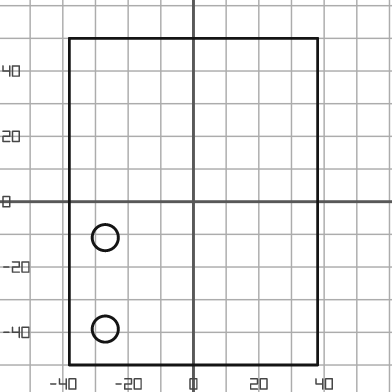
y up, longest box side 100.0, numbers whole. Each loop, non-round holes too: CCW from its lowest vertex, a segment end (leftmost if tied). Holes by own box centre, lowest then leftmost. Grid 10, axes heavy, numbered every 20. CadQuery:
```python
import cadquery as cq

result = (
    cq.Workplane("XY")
    .moveTo(-38.0, -50.0)
    .lineTo(38.0, -50.0)
    .lineTo(38.0, 50.0)
    .lineTo(-38.0, 50.0)
    .close()
    .moveTo(-27.0, -39.0)
    .circle(4.0)
    .moveTo(-27.0, -11.0)
    .circle(4.0)
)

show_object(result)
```